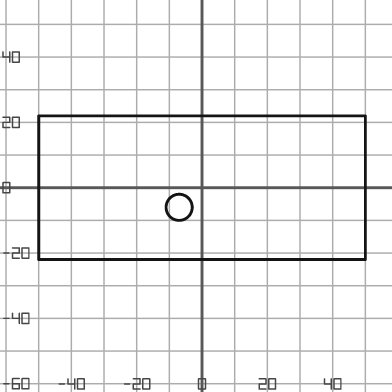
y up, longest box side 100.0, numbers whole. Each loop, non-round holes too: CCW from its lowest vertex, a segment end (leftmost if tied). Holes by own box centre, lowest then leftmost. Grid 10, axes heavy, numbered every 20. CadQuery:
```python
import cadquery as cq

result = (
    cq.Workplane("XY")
    .moveTo(-50.0, -22.0)
    .lineTo(50.0, -22.0)
    .lineTo(50.0, 22.0)
    .lineTo(-50.0, 22.0)
    .close()
    .moveTo(-7.0, -6.0)
    .circle(4.0)
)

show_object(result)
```